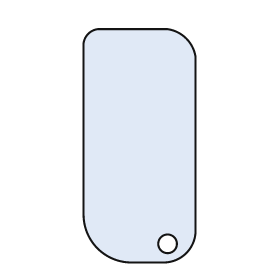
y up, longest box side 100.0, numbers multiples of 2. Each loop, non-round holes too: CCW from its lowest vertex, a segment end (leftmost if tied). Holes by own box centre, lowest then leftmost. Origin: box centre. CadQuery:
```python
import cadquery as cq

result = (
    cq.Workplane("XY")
    .moveTo(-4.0, -50.0)
    .lineTo(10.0, -50.0)
    .threePointArc((20.0, -46.0), (24.0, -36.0))
    .lineTo(24.0, 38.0)
    .threePointArc((20.0, 46.0), (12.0, 50.0))
    .lineTo(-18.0, 50.0)
    .threePointArc((-22.0, 48.0), (-24.0, 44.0))
    .lineTo(-24.0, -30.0)
    .threePointArc((-18.0, -44.0), (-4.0, -50.0))
    .close()
    .moveTo(12.0, -42.0)
    .circle(4.0)
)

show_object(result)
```